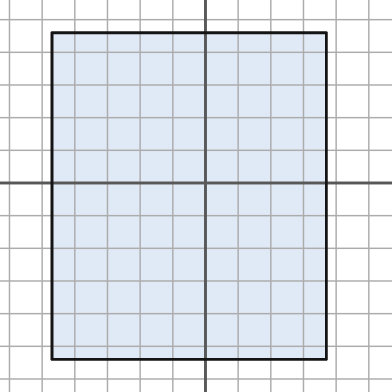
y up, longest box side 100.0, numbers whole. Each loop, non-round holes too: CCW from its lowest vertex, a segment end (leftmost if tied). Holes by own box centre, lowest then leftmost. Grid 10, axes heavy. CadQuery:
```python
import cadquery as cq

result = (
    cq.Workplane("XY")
    .moveTo(-47.0, -54.0)
    .lineTo(37.0, -54.0)
    .lineTo(37.0, 46.0)
    .lineTo(-47.0, 46.0)
    .close()
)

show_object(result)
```